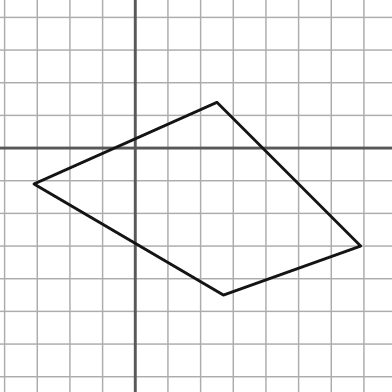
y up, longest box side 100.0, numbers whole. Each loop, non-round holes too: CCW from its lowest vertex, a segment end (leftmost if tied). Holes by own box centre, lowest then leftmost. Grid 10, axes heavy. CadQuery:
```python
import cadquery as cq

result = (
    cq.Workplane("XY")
    .moveTo(27.0, -45.0)
    .lineTo(69.0, -30.0)
    .lineTo(25.0, 14.0)
    .lineTo(-31.0, -11.0)
    .close()
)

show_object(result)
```